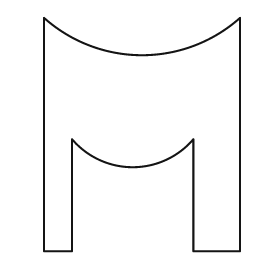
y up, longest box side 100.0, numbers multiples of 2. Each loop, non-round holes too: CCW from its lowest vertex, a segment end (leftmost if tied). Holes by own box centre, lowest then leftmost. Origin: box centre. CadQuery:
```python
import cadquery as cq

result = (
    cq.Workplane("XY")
    .moveTo(-42.0, -50.0)
    .lineTo(-30.0, -50.0)
    .lineTo(-30.0, -2.0)
    .threePointArc((-4.0, -14.0), (22.0, -2.0))
    .lineTo(22.0, -50.0)
    .lineTo(42.0, -50.0)
    .lineTo(42.0, 50.0)
    .threePointArc((0.0, 34.0), (-42.0, 50.0))
    .close()
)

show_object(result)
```